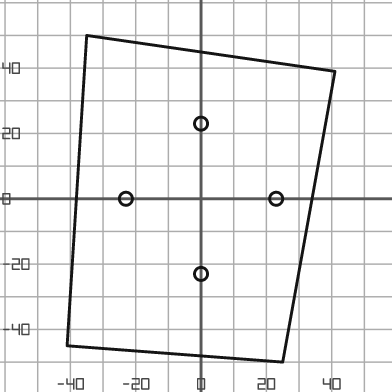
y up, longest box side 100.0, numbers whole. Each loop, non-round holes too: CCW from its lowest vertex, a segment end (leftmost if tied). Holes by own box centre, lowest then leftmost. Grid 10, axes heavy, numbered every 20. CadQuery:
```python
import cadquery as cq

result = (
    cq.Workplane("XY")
    .moveTo(25.0, -50.0)
    .lineTo(41.0, 39.0)
    .lineTo(-35.0, 50.0)
    .lineTo(-41.0, -45.0)
    .close()
    .moveTo(0.0, -23.0)
    .circle(2.0)
    .moveTo(-23.0, 0.0)
    .circle(2.0)
    .moveTo(23.0, 0.0)
    .circle(2.0)
    .moveTo(0.0, 23.0)
    .circle(2.0)
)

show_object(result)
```